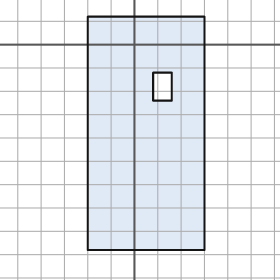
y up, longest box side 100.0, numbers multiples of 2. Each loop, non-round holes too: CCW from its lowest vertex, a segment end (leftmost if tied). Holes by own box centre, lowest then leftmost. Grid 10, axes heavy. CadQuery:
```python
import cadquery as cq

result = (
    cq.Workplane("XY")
    .moveTo(-20.0, -88.0)
    .lineTo(30.0, -88.0)
    .lineTo(30.0, 12.0)
    .lineTo(-20.0, 12.0)
    .close()
    .moveTo(8.0, -24.0)
    .lineTo(16.0, -24.0)
    .lineTo(16.0, -12.0)
    .lineTo(8.0, -12.0)
    .close()
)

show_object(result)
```